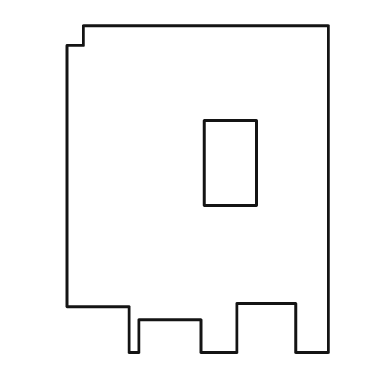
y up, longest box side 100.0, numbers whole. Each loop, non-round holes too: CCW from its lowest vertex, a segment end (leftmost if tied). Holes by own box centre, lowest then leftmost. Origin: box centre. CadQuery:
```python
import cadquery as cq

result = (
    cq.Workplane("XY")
    .moveTo(-21.0, -50.0)
    .lineTo(-18.0, -50.0)
    .lineTo(-18.0, -40.0)
    .lineTo(1.0, -40.0)
    .lineTo(1.0, -50.0)
    .lineTo(12.0, -50.0)
    .lineTo(12.0, -35.0)
    .lineTo(30.0, -35.0)
    .lineTo(30.0, -50.0)
    .lineTo(40.0, -50.0)
    .lineTo(40.0, 50.0)
    .lineTo(-35.0, 50.0)
    .lineTo(-35.0, 44.0)
    .lineTo(-40.0, 44.0)
    .lineTo(-40.0, -36.0)
    .lineTo(-21.0, -36.0)
    .close()
    .moveTo(2.0, -5.0)
    .lineTo(18.0, -5.0)
    .lineTo(18.0, 21.0)
    .lineTo(2.0, 21.0)
    .close()
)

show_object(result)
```